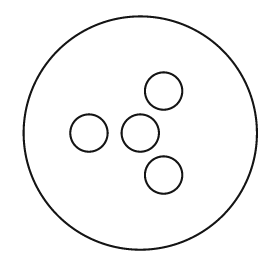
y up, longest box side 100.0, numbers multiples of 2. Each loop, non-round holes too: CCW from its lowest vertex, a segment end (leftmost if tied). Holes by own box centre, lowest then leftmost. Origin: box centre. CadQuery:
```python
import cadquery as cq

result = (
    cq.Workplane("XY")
    .moveTo(0.0, 0.0)
    .circle(50.0)
    .moveTo(10.0, -18.0)
    .circle(8.0)
    .moveTo(-22.0, 0.0)
    .circle(8.0)
    .moveTo(0.0, 0.0)
    .circle(8.0)
    .moveTo(10.0, 18.0)
    .circle(8.0)
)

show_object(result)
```